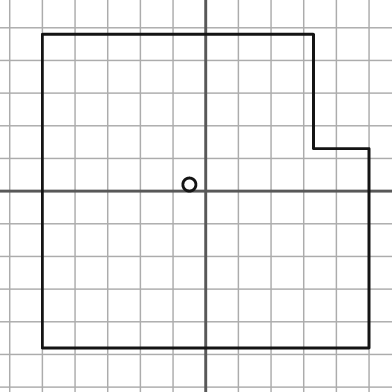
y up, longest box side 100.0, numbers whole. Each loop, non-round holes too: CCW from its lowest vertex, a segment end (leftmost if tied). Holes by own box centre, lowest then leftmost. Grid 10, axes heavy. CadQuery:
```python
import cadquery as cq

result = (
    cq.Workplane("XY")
    .moveTo(-50.0, -48.0)
    .lineTo(50.0, -48.0)
    .lineTo(50.0, 13.0)
    .lineTo(33.0, 13.0)
    .lineTo(33.0, 48.0)
    .lineTo(-50.0, 48.0)
    .close()
    .moveTo(-5.0, 2.0)
    .circle(2.0)
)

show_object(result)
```